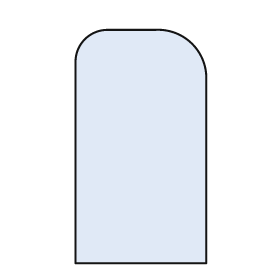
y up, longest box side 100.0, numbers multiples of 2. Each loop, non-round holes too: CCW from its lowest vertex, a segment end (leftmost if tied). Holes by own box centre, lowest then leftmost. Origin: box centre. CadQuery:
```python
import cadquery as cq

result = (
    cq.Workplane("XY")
    .moveTo(-28.0, -50.0)
    .lineTo(28.0, -50.0)
    .lineTo(28.0, 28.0)
    .threePointArc((22.0, 44.0), (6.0, 50.0))
    .lineTo(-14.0, 50.0)
    .threePointArc((-24.0, 46.0), (-28.0, 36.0))
    .close()
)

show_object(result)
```